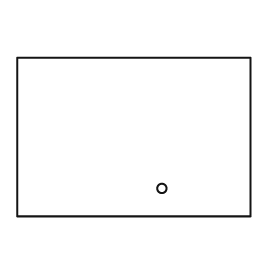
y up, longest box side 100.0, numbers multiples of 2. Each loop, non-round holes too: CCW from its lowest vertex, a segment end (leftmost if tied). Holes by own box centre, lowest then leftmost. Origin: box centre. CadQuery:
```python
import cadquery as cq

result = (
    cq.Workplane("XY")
    .moveTo(-50.0, -34.0)
    .lineTo(50.0, -34.0)
    .lineTo(50.0, 34.0)
    .lineTo(-50.0, 34.0)
    .close()
    .moveTo(12.0, -22.0)
    .circle(2.0)
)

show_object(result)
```